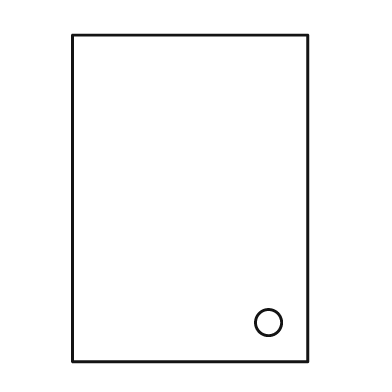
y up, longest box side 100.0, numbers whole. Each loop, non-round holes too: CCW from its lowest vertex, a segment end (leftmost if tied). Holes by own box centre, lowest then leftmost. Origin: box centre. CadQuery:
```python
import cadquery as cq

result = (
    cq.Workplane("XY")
    .moveTo(-36.0, -50.0)
    .lineTo(36.0, -50.0)
    .lineTo(36.0, 50.0)
    .lineTo(-36.0, 50.0)
    .close()
    .moveTo(24.0, -38.0)
    .circle(4.0)
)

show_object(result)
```